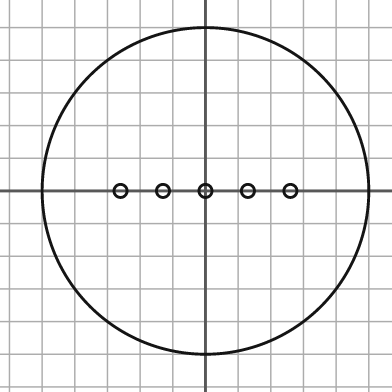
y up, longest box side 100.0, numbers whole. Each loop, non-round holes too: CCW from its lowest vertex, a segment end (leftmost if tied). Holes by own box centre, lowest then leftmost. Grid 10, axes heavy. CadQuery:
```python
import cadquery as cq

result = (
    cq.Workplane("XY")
    .moveTo(0.0, 0.0)
    .circle(50.0)
    .moveTo(-26.0, 0.0)
    .circle(2.0)
    .moveTo(-13.0, 0.0)
    .circle(2.0)
    .moveTo(0.0, 0.0)
    .circle(2.0)
    .moveTo(13.0, 0.0)
    .circle(2.0)
    .moveTo(26.0, 0.0)
    .circle(2.0)
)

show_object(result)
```